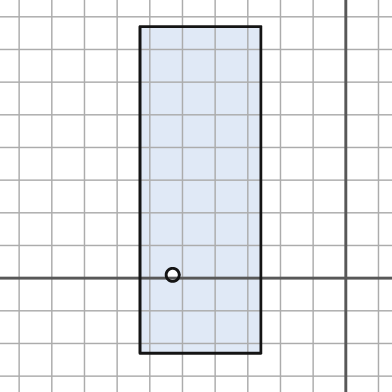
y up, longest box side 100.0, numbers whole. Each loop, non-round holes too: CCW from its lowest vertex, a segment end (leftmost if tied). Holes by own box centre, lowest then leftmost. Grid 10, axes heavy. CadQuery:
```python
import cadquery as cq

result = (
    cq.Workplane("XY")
    .moveTo(-63.0, -23.0)
    .lineTo(-26.0, -23.0)
    .lineTo(-26.0, 77.0)
    .lineTo(-63.0, 77.0)
    .close()
    .moveTo(-53.0, 1.0)
    .circle(2.0)
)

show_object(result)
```